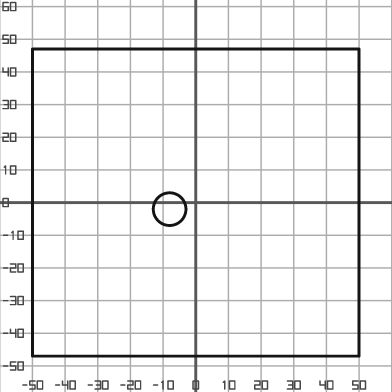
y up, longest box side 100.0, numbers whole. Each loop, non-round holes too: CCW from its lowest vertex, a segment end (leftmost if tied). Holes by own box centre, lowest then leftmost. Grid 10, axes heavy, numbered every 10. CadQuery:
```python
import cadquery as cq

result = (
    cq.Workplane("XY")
    .moveTo(-50.0, -47.0)
    .lineTo(50.0, -47.0)
    .lineTo(50.0, 47.0)
    .lineTo(-50.0, 47.0)
    .close()
    .moveTo(-8.0, -2.0)
    .circle(5.0)
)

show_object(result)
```